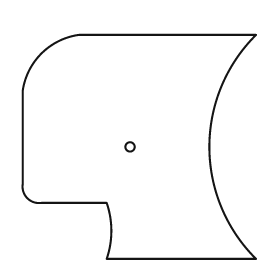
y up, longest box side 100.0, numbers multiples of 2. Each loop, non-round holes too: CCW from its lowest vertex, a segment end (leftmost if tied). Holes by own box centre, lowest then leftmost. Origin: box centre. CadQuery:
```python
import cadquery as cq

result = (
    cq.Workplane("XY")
    .moveTo(-14.0, -48.0)
    .lineTo(50.0, -48.0)
    .threePointArc((30.0, 0.0), (50.0, 48.0))
    .lineTo(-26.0, 48.0)
    .threePointArc((-42.0, 40.0), (-50.0, 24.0))
    .lineTo(-50.0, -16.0)
    .threePointArc((-48.0, -22.0), (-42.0, -24.0))
    .lineTo(-14.0, -24.0)
    .threePointArc((-12.0, -36.0), (-14.0, -48.0))
    .close()
    .moveTo(-4.0, 0.0)
    .circle(2.0)
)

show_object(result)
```